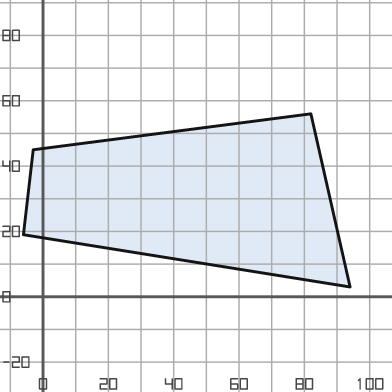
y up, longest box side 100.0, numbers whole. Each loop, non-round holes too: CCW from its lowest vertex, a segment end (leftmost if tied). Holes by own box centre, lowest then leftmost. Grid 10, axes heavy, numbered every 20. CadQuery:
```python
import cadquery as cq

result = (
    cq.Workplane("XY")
    .moveTo(94.0, 3.0)
    .lineTo(82.0, 56.0)
    .lineTo(-3.0, 45.0)
    .lineTo(-6.0, 19.0)
    .close()
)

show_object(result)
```